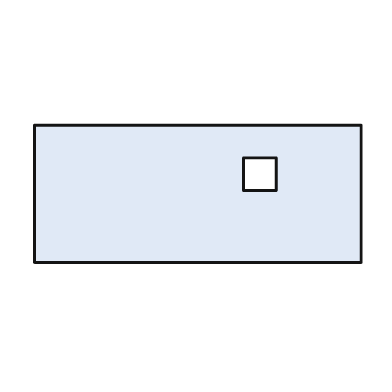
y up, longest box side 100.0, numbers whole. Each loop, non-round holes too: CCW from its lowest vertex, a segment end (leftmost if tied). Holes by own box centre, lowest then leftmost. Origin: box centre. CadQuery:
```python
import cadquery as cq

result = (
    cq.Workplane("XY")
    .moveTo(-50.0, -21.0)
    .lineTo(50.0, -21.0)
    .lineTo(50.0, 21.0)
    .lineTo(-50.0, 21.0)
    .close()
    .moveTo(14.0, 1.0)
    .lineTo(24.0, 1.0)
    .lineTo(24.0, 11.0)
    .lineTo(14.0, 11.0)
    .close()
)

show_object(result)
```